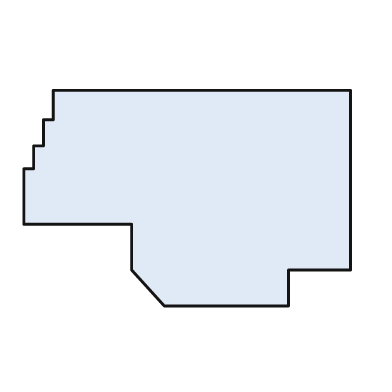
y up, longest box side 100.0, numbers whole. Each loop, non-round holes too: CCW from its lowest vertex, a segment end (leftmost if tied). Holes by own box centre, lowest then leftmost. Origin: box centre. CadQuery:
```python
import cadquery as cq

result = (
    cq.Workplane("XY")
    .moveTo(-7.0, -33.0)
    .lineTo(31.0, -33.0)
    .lineTo(31.0, -22.0)
    .lineTo(50.0, -22.0)
    .lineTo(50.0, 33.0)
    .lineTo(-41.0, 33.0)
    .lineTo(-41.0, 24.0)
    .lineTo(-44.0, 24.0)
    .lineTo(-44.0, 16.0)
    .lineTo(-47.0, 16.0)
    .lineTo(-47.0, 9.0)
    .lineTo(-50.0, 9.0)
    .lineTo(-50.0, -8.0)
    .lineTo(-17.0, -8.0)
    .lineTo(-17.0, -22.0)
    .close()
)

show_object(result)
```